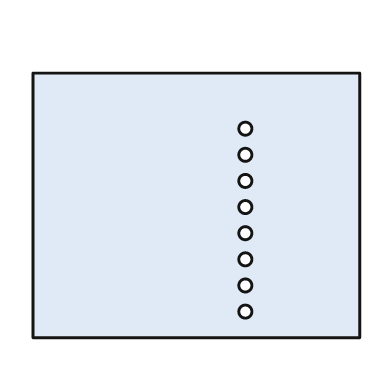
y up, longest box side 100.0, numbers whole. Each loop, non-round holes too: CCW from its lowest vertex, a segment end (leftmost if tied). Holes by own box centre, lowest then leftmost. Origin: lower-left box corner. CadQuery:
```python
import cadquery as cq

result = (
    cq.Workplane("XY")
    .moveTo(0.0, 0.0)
    .lineTo(100.0, 0.0)
    .lineTo(100.0, 81.0)
    .lineTo(0.0, 81.0)
    .close()
    .moveTo(65.0, 8.0)
    .circle(2.0)
    .moveTo(65.0, 16.0)
    .circle(2.0)
    .moveTo(65.0, 24.0)
    .circle(2.0)
    .moveTo(65.0, 32.0)
    .circle(2.0)
    .moveTo(65.0, 40.0)
    .circle(2.0)
    .moveTo(65.0, 48.0)
    .circle(2.0)
    .moveTo(65.0, 56.0)
    .circle(2.0)
    .moveTo(65.0, 64.0)
    .circle(2.0)
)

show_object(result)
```